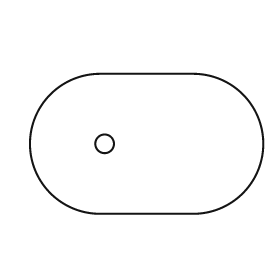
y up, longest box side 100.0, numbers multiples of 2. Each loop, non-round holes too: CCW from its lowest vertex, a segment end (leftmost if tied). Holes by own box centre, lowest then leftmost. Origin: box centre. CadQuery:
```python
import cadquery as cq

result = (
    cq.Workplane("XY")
    .moveTo(-20.0, -30.0)
    .lineTo(20.0, -30.0)
    .threePointArc((50.0, 0.0), (20.0, 30.0))
    .lineTo(-20.0, 30.0)
    .threePointArc((-50.0, 0.0), (-20.0, -30.0))
    .close()
    .moveTo(-18.0, 0.0)
    .circle(4.0)
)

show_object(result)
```